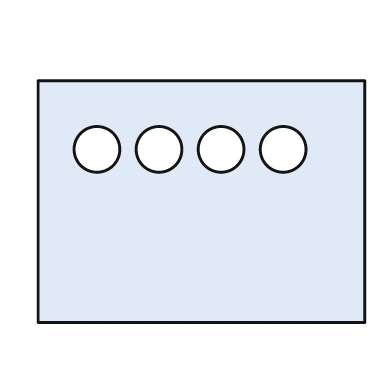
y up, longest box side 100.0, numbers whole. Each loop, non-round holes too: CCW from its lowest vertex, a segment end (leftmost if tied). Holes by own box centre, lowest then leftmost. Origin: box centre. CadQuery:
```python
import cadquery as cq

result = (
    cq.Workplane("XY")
    .moveTo(-50.0, -37.0)
    .lineTo(50.0, -37.0)
    .lineTo(50.0, 37.0)
    .lineTo(-50.0, 37.0)
    .close()
    .moveTo(-32.0, 16.0)
    .circle(7.0)
    .moveTo(-13.0, 16.0)
    .circle(7.0)
    .moveTo(6.0, 16.0)
    .circle(7.0)
    .moveTo(25.0, 16.0)
    .circle(7.0)
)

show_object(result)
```